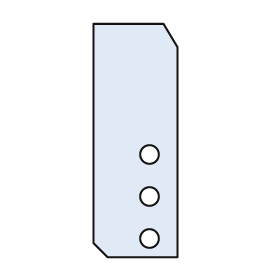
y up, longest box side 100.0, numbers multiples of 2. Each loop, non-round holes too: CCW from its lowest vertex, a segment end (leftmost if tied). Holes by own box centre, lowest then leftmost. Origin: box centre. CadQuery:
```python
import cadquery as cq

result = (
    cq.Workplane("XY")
    .moveTo(-12.0, -50.0)
    .lineTo(18.0, -50.0)
    .lineTo(18.0, 40.0)
    .lineTo(12.0, 50.0)
    .lineTo(-18.0, 50.0)
    .lineTo(-18.0, -44.0)
    .close()
    .moveTo(6.0, -42.0)
    .circle(4.0)
    .moveTo(6.0, -24.0)
    .circle(4.0)
    .moveTo(6.0, -6.0)
    .circle(4.0)
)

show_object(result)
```